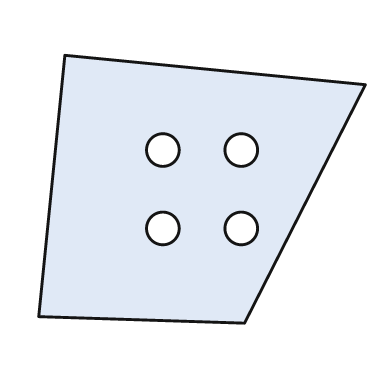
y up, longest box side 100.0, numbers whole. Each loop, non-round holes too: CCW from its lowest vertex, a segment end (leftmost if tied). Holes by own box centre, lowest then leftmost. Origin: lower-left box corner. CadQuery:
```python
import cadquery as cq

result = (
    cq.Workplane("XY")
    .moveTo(63.0, 0.0)
    .lineTo(100.0, 73.0)
    .lineTo(8.0, 82.0)
    .lineTo(0.0, 2.0)
    .close()
    .moveTo(38.0, 29.0)
    .circle(5.0)
    .moveTo(62.0, 29.0)
    .circle(5.0)
    .moveTo(38.0, 53.0)
    .circle(5.0)
    .moveTo(62.0, 53.0)
    .circle(5.0)
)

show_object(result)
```